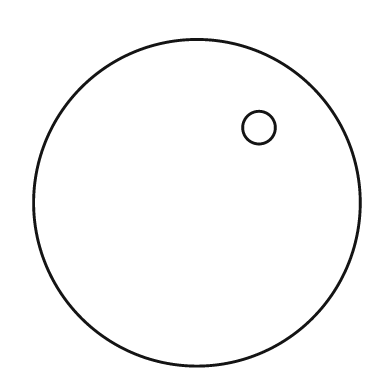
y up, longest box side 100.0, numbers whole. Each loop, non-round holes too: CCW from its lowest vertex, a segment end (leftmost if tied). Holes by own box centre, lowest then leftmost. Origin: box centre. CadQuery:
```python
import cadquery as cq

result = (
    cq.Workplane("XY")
    .moveTo(0.0, 0.0)
    .circle(50.0)
    .moveTo(19.0, 23.0)
    .circle(5.0)
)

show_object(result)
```